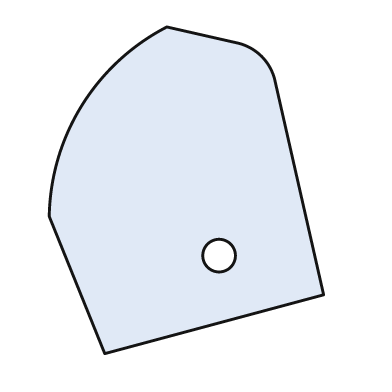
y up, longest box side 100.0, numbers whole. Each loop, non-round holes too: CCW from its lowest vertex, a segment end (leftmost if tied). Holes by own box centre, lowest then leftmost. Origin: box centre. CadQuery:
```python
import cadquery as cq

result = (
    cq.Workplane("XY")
    .moveTo(-25.0, -50.0)
    .lineTo(42.0, -32.0)
    .lineTo(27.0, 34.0)
    .threePointArc((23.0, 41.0), (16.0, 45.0))
    .lineTo(-6.0, 50.0)
    .threePointArc((-32.0, 26.0), (-42.0, -8.0))
    .close()
    .moveTo(10.0, -20.0)
    .circle(5.0)
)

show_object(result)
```